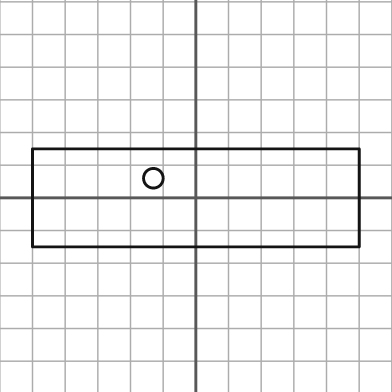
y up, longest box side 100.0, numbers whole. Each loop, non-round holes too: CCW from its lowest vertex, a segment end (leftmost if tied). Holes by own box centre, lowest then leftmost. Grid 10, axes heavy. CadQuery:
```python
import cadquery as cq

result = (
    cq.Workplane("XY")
    .moveTo(-50.0, -15.0)
    .lineTo(50.0, -15.0)
    .lineTo(50.0, 15.0)
    .lineTo(-50.0, 15.0)
    .close()
    .moveTo(-13.0, 6.0)
    .circle(3.0)
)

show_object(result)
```